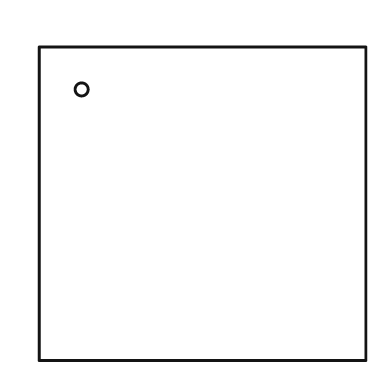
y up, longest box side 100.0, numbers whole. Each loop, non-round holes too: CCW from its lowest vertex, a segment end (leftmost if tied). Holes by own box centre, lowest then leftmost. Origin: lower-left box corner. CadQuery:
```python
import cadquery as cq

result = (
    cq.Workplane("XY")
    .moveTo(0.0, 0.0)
    .lineTo(100.0, 0.0)
    .lineTo(100.0, 96.0)
    .lineTo(0.0, 96.0)
    .close()
    .moveTo(13.0, 83.0)
    .circle(2.0)
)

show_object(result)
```